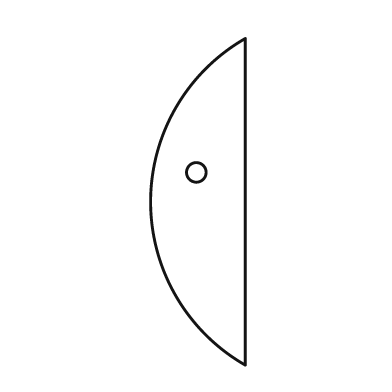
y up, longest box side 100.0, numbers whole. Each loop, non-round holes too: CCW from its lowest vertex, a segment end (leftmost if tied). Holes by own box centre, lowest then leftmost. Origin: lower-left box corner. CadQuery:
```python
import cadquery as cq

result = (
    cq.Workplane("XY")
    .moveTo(29.0, 0.0)
    .lineTo(29.0, 100.0)
    .threePointArc((0.0, 50.0), (29.0, 0.0))
    .close()
    .moveTo(14.0, 59.0)
    .circle(3.0)
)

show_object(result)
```